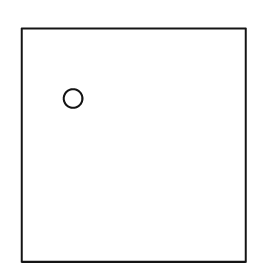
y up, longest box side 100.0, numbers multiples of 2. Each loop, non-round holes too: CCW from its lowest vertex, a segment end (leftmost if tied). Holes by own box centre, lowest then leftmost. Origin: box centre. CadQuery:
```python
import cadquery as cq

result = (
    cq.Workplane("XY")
    .moveTo(-48.0, -50.0)
    .lineTo(48.0, -50.0)
    .lineTo(48.0, 50.0)
    .lineTo(-48.0, 50.0)
    .close()
    .moveTo(-26.0, 20.0)
    .circle(4.0)
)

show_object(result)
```